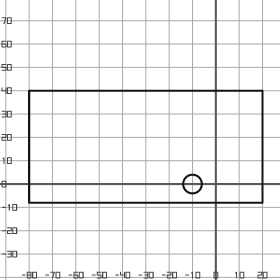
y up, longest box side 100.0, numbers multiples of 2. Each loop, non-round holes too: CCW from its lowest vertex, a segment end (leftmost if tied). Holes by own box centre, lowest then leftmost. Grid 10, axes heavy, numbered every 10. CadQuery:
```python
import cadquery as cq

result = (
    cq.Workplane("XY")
    .moveTo(-80.0, -8.0)
    .lineTo(20.0, -8.0)
    .lineTo(20.0, 40.0)
    .lineTo(-80.0, 40.0)
    .close()
    .moveTo(-10.0, 0.0)
    .circle(4.0)
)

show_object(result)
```